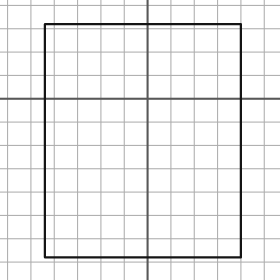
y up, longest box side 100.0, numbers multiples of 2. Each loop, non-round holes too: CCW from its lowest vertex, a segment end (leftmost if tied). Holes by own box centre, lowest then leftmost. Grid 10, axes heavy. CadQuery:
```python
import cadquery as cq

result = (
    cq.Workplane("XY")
    .moveTo(-44.0, -68.0)
    .lineTo(40.0, -68.0)
    .lineTo(40.0, 32.0)
    .lineTo(-44.0, 32.0)
    .close()
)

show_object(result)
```